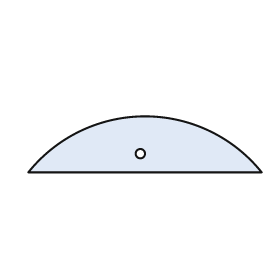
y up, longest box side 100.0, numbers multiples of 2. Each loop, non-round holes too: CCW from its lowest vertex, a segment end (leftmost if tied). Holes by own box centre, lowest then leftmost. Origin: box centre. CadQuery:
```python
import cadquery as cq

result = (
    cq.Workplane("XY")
    .moveTo(-50.0, -12.0)
    .lineTo(50.0, -12.0)
    .threePointArc((0.0, 12.0), (-50.0, -12.0))
    .close()
    .moveTo(-2.0, -4.0)
    .circle(2.0)
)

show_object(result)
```